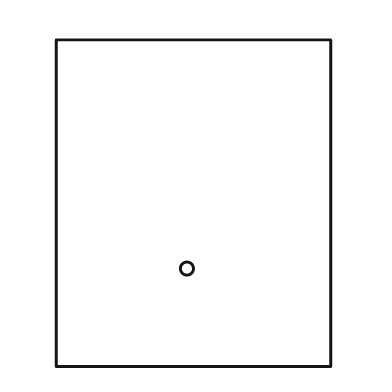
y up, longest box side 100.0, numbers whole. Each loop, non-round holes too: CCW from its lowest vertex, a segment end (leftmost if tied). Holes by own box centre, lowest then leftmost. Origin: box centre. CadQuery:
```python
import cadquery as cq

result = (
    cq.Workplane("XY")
    .moveTo(-42.0, -50.0)
    .lineTo(42.0, -50.0)
    .lineTo(42.0, 50.0)
    .lineTo(-42.0, 50.0)
    .close()
    .moveTo(-2.0, -20.0)
    .circle(2.0)
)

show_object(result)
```